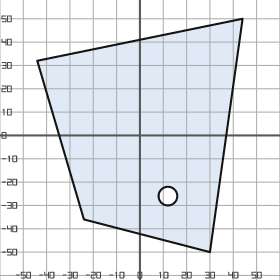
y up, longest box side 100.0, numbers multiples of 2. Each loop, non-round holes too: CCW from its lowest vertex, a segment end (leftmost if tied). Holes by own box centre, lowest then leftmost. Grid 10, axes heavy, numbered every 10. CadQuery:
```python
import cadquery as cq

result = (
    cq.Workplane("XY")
    .moveTo(30.0, -50.0)
    .lineTo(44.0, 50.0)
    .lineTo(-44.0, 32.0)
    .lineTo(-24.0, -36.0)
    .close()
    .moveTo(12.0, -26.0)
    .circle(4.0)
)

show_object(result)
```